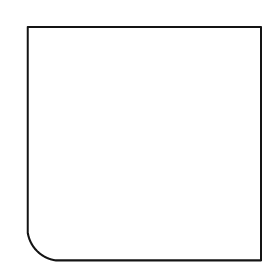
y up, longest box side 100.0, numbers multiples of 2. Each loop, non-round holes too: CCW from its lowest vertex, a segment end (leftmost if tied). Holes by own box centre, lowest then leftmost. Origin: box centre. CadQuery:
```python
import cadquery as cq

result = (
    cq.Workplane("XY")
    .moveTo(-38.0, -50.0)
    .lineTo(50.0, -50.0)
    .lineTo(50.0, 50.0)
    .lineTo(-50.0, 50.0)
    .lineTo(-50.0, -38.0)
    .threePointArc((-46.0, -46.0), (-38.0, -50.0))
    .close()
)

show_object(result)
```